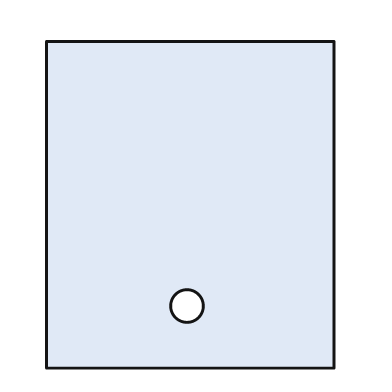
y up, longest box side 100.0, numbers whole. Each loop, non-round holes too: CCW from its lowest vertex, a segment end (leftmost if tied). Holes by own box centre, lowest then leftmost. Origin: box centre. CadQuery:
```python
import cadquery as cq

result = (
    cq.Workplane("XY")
    .moveTo(-44.0, -50.0)
    .lineTo(44.0, -50.0)
    .lineTo(44.0, 50.0)
    .lineTo(-44.0, 50.0)
    .close()
    .moveTo(-1.0, -31.0)
    .circle(5.0)
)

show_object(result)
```